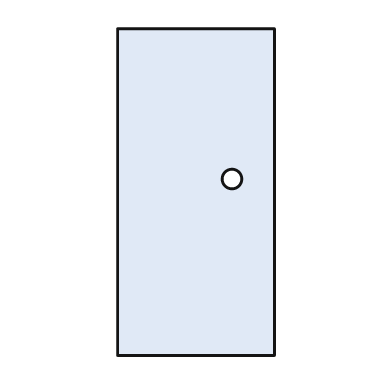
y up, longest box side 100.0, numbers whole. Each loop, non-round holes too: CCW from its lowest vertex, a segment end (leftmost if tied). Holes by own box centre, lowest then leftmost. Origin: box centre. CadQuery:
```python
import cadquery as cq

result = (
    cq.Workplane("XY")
    .moveTo(-24.0, -50.0)
    .lineTo(24.0, -50.0)
    .lineTo(24.0, 50.0)
    .lineTo(-24.0, 50.0)
    .close()
    .moveTo(11.0, 4.0)
    .circle(3.0)
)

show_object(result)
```